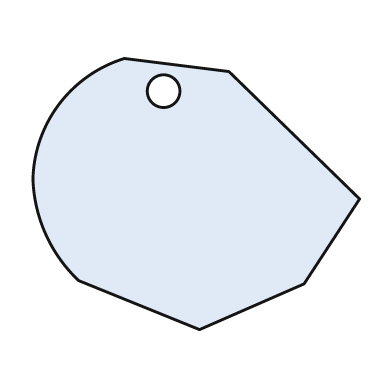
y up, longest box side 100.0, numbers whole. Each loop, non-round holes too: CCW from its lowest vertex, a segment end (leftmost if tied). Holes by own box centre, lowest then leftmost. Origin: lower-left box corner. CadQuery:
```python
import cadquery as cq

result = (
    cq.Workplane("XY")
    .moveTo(51.0, 0.0)
    .lineTo(83.0, 14.0)
    .lineTo(100.0, 40.0)
    .lineTo(60.0, 79.0)
    .lineTo(28.0, 83.0)
    .threePointArc((8.0, 69.0), (0.0, 46.0))
    .threePointArc((4.0, 29.0), (14.0, 15.0))
    .close()
    .moveTo(40.0, 73.0)
    .circle(5.0)
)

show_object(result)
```